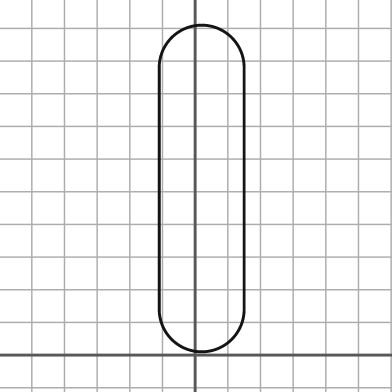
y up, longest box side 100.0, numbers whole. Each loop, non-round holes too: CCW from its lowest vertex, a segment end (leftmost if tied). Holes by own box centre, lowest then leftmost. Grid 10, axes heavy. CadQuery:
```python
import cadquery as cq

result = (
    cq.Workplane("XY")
    .moveTo(-11.0, 14.0)
    .threePointArc((2.0, 1.0), (15.0, 14.0))
    .lineTo(15.0, 88.0)
    .threePointArc((2.0, 101.0), (-11.0, 88.0))
    .close()
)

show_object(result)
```